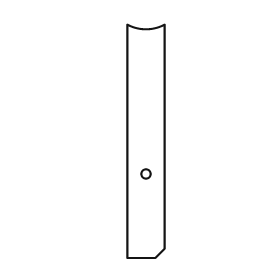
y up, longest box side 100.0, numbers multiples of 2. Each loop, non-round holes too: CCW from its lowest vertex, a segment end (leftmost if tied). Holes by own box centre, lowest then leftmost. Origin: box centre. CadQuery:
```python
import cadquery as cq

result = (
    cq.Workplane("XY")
    .moveTo(-8.0, -50.0)
    .lineTo(4.0, -50.0)
    .lineTo(8.0, -46.0)
    .lineTo(8.0, 50.0)
    .threePointArc((0.0, 48.0), (-8.0, 50.0))
    .close()
    .moveTo(0.0, -14.0)
    .circle(2.0)
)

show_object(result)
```